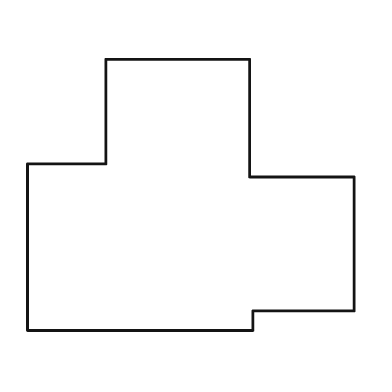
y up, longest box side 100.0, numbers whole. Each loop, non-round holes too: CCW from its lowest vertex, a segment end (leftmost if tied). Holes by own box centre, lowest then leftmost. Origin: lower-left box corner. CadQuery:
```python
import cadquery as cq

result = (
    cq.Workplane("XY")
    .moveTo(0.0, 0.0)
    .lineTo(69.0, 0.0)
    .lineTo(69.0, 6.0)
    .lineTo(100.0, 6.0)
    .lineTo(100.0, 47.0)
    .lineTo(68.0, 47.0)
    .lineTo(68.0, 83.0)
    .lineTo(24.0, 83.0)
    .lineTo(24.0, 51.0)
    .lineTo(0.0, 51.0)
    .close()
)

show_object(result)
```